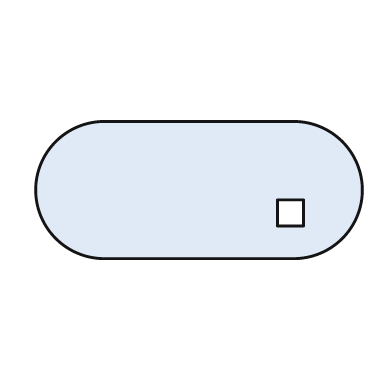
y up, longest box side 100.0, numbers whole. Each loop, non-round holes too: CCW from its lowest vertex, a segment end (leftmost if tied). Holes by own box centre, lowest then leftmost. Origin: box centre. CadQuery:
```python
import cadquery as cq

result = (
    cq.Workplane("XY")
    .moveTo(-29.0, -21.0)
    .lineTo(29.0, -21.0)
    .threePointArc((50.0, 0.0), (29.0, 21.0))
    .lineTo(-29.0, 21.0)
    .threePointArc((-50.0, 0.0), (-29.0, -21.0))
    .close()
    .moveTo(24.0, -11.0)
    .lineTo(32.0, -11.0)
    .lineTo(32.0, -3.0)
    .lineTo(24.0, -3.0)
    .close()
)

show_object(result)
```